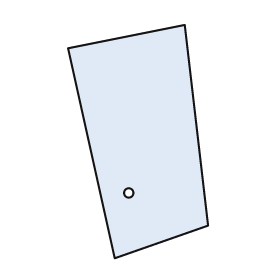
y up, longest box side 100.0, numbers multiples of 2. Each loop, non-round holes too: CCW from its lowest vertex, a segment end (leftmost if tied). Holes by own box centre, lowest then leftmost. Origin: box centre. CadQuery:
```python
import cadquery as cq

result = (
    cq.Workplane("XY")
    .moveTo(-10.0, -50.0)
    .lineTo(30.0, -36.0)
    .lineTo(20.0, 50.0)
    .lineTo(-30.0, 40.0)
    .close()
    .moveTo(-4.0, -22.0)
    .circle(2.0)
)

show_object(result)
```